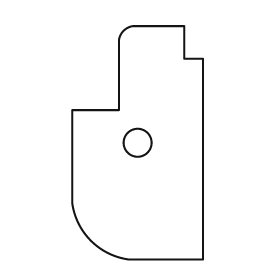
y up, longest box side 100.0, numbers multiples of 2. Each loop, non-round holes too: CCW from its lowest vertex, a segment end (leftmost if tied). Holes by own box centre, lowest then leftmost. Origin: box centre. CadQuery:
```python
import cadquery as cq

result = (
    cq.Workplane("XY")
    .moveTo(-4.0, -50.0)
    .lineTo(28.0, -50.0)
    .lineTo(28.0, 36.0)
    .lineTo(20.0, 36.0)
    .lineTo(20.0, 50.0)
    .lineTo(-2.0, 50.0)
    .threePointArc((-6.0, 48.0), (-8.0, 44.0))
    .lineTo(-8.0, 14.0)
    .lineTo(-28.0, 14.0)
    .lineTo(-28.0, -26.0)
    .threePointArc((-20.0, -42.0), (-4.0, -50.0))
    .close()
    .moveTo(0.0, 0.0)
    .circle(6.0)
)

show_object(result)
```